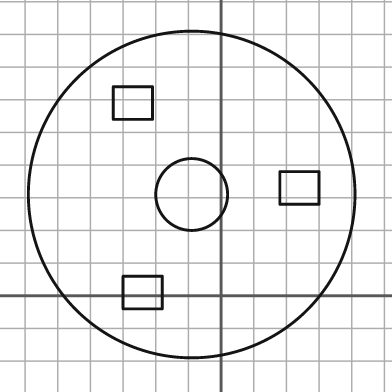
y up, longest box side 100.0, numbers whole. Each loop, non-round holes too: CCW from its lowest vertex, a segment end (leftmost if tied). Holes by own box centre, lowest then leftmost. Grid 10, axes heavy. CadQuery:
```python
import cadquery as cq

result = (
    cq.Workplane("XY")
    .moveTo(-9.0, 31.0)
    .circle(50.0)
    .moveTo(-30.0, -4.0)
    .lineTo(-18.0, -4.0)
    .lineTo(-18.0, 6.0)
    .lineTo(-30.0, 6.0)
    .close()
    .moveTo(-9.0, 31.0)
    .circle(11.0)
    .moveTo(18.0, 28.0)
    .lineTo(30.0, 28.0)
    .lineTo(30.0, 38.0)
    .lineTo(18.0, 38.0)
    .close()
    .moveTo(-33.0, 54.0)
    .lineTo(-21.0, 54.0)
    .lineTo(-21.0, 64.0)
    .lineTo(-33.0, 64.0)
    .close()
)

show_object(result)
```